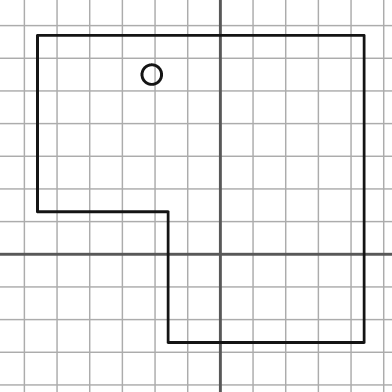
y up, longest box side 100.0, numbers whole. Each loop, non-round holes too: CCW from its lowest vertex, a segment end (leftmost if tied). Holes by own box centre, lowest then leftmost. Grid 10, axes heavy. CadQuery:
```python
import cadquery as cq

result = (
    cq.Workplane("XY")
    .moveTo(-16.0, -27.0)
    .lineTo(44.0, -27.0)
    .lineTo(44.0, 67.0)
    .lineTo(-56.0, 67.0)
    .lineTo(-56.0, 13.0)
    .lineTo(-16.0, 13.0)
    .close()
    .moveTo(-21.0, 55.0)
    .circle(3.0)
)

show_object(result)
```